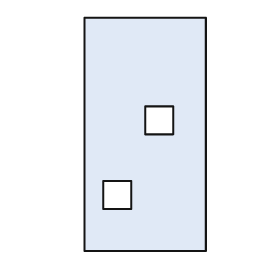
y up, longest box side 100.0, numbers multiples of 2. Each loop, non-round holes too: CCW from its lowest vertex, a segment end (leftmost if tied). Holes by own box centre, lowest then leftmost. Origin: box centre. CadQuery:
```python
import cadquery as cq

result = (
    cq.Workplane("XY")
    .moveTo(-26.0, -50.0)
    .lineTo(26.0, -50.0)
    .lineTo(26.0, 50.0)
    .lineTo(-26.0, 50.0)
    .close()
    .moveTo(-18.0, -32.0)
    .lineTo(-6.0, -32.0)
    .lineTo(-6.0, -20.0)
    .lineTo(-18.0, -20.0)
    .close()
    .moveTo(0.0, 0.0)
    .lineTo(12.0, 0.0)
    .lineTo(12.0, 12.0)
    .lineTo(0.0, 12.0)
    .close()
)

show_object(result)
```